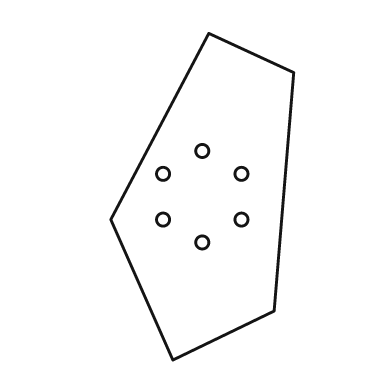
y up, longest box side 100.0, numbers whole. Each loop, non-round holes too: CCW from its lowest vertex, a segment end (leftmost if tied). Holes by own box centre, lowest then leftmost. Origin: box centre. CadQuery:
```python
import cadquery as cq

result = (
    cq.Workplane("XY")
    .moveTo(-9.0, -50.0)
    .lineTo(22.0, -35.0)
    .lineTo(28.0, 38.0)
    .lineTo(2.0, 50.0)
    .lineTo(-28.0, -7.0)
    .close()
    .moveTo(0.0, -14.0)
    .circle(2.0)
    .moveTo(-12.0, -7.0)
    .circle(2.0)
    .moveTo(12.0, -7.0)
    .circle(2.0)
    .moveTo(-12.0, 7.0)
    .circle(2.0)
    .moveTo(12.0, 7.0)
    .circle(2.0)
    .moveTo(0.0, 14.0)
    .circle(2.0)
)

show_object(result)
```